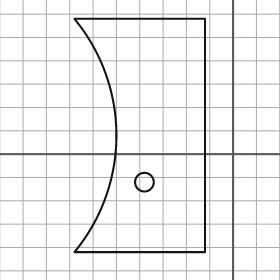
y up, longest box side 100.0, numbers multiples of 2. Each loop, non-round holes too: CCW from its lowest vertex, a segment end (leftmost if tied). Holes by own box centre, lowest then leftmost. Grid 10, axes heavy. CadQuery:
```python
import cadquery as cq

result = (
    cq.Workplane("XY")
    .moveTo(-68.0, -42.0)
    .lineTo(-12.0, -42.0)
    .lineTo(-12.0, 58.0)
    .lineTo(-68.0, 58.0)
    .threePointArc((-50.0, 8.0), (-68.0, -42.0))
    .close()
    .moveTo(-38.0, -12.0)
    .circle(4.0)
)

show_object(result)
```